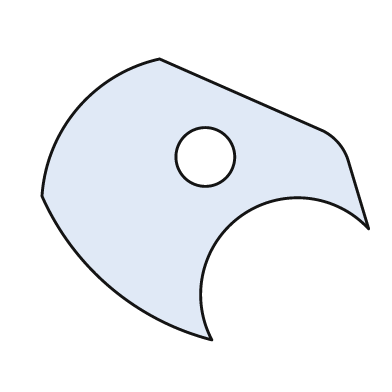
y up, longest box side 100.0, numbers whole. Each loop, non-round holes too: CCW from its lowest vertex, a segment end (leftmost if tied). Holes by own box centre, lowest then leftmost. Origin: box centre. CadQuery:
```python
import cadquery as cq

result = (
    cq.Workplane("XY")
    .moveTo(2.0, -43.0)
    .threePointArc((11.0, -5.0), (50.0, -9.0))
    .lineTo(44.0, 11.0)
    .threePointArc((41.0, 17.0), (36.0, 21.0))
    .lineTo(-14.0, 43.0)
    .threePointArc((-39.0, 28.0), (-50.0, 1.0))
    .threePointArc((-29.0, -27.0), (2.0, -43.0))
    .close()
    .moveTo(0.0, 13.0)
    .circle(9.0)
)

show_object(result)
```